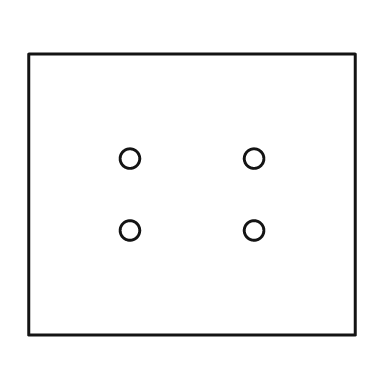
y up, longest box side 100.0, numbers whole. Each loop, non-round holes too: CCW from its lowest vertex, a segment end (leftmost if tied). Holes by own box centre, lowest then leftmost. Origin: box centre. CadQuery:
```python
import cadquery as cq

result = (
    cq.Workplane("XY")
    .moveTo(-50.0, -43.0)
    .lineTo(50.0, -43.0)
    .lineTo(50.0, 43.0)
    .lineTo(-50.0, 43.0)
    .close()
    .moveTo(-19.0, -11.0)
    .circle(3.0)
    .moveTo(19.0, -11.0)
    .circle(3.0)
    .moveTo(-19.0, 11.0)
    .circle(3.0)
    .moveTo(19.0, 11.0)
    .circle(3.0)
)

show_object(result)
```